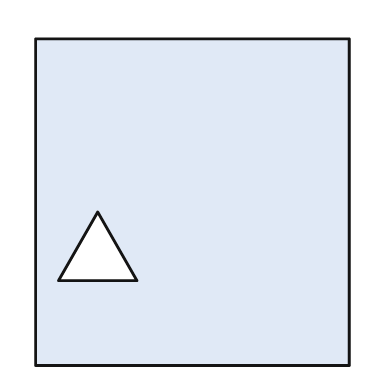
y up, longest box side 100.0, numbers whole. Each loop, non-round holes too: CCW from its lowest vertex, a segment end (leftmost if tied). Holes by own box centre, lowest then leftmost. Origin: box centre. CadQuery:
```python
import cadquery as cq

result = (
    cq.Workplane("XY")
    .moveTo(-48.0, -50.0)
    .lineTo(48.0, -50.0)
    .lineTo(48.0, 50.0)
    .lineTo(-48.0, 50.0)
    .close()
    .moveTo(-41.0, -24.0)
    .lineTo(-17.0, -24.0)
    .lineTo(-29.0, -3.0)
    .close()
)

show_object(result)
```